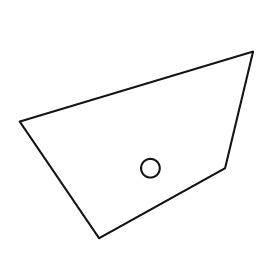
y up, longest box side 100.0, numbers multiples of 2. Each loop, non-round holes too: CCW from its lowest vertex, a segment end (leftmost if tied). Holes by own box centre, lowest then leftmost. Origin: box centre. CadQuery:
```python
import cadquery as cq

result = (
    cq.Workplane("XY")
    .moveTo(-16.0, -40.0)
    .lineTo(38.0, -10.0)
    .lineTo(50.0, 40.0)
    .lineTo(-50.0, 10.0)
    .close()
    .moveTo(6.0, -10.0)
    .circle(4.0)
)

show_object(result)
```